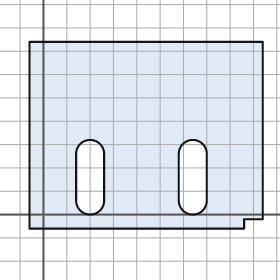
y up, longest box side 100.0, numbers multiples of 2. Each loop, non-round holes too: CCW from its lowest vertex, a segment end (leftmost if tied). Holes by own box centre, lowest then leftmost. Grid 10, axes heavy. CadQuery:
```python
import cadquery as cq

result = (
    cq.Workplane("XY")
    .moveTo(-6.0, -6.0)
    .lineTo(86.0, -6.0)
    .lineTo(86.0, -2.0)
    .lineTo(94.0, -2.0)
    .lineTo(94.0, 74.0)
    .lineTo(-6.0, 74.0)
    .close()
    .moveTo(14.0, 6.0)
    .threePointArc((20.0, 0.0), (26.0, 6.0))
    .lineTo(26.0, 26.0)
    .threePointArc((20.0, 32.0), (14.0, 26.0))
    .close()
    .moveTo(58.0, 6.0)
    .threePointArc((64.0, 0.0), (70.0, 6.0))
    .lineTo(70.0, 26.0)
    .threePointArc((64.0, 32.0), (58.0, 26.0))
    .close()
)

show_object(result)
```